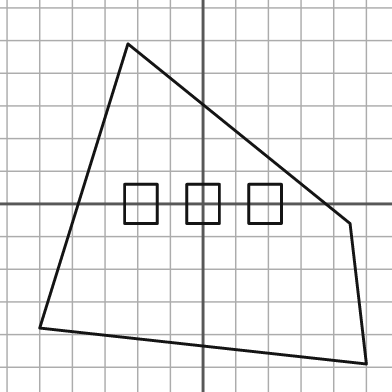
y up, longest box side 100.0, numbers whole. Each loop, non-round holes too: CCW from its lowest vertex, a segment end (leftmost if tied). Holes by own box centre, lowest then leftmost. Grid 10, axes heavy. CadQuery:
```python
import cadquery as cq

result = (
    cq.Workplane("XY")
    .moveTo(50.0, -49.0)
    .lineTo(45.0, -6.0)
    .lineTo(-23.0, 49.0)
    .lineTo(-50.0, -38.0)
    .close()
    .moveTo(-24.0, -6.0)
    .lineTo(-14.0, -6.0)
    .lineTo(-14.0, 6.0)
    .lineTo(-24.0, 6.0)
    .close()
    .moveTo(-5.0, -6.0)
    .lineTo(5.0, -6.0)
    .lineTo(5.0, 6.0)
    .lineTo(-5.0, 6.0)
    .close()
    .moveTo(14.0, -6.0)
    .lineTo(24.0, -6.0)
    .lineTo(24.0, 6.0)
    .lineTo(14.0, 6.0)
    .close()
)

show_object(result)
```